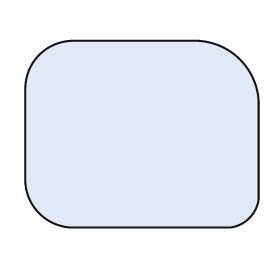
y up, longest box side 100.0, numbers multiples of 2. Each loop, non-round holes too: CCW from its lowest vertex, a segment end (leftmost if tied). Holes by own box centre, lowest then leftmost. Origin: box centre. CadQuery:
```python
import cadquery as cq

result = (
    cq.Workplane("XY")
    .moveTo(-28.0, -40.0)
    .lineTo(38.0, -40.0)
    .threePointArc((46.0, -36.0), (50.0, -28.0))
    .lineTo(50.0, 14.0)
    .threePointArc((42.0, 32.0), (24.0, 40.0))
    .lineTo(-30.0, 40.0)
    .threePointArc((-44.0, 34.0), (-50.0, 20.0))
    .lineTo(-50.0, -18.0)
    .threePointArc((-44.0, -34.0), (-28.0, -40.0))
    .close()
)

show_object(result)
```